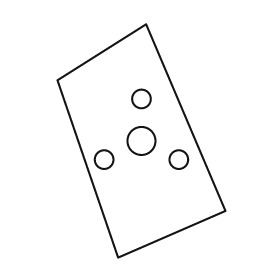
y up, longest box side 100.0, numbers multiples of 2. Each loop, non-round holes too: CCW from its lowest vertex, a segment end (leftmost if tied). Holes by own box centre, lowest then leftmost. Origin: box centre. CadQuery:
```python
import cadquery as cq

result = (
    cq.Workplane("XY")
    .moveTo(-10.0, -50.0)
    .lineTo(36.0, -30.0)
    .lineTo(2.0, 50.0)
    .lineTo(-36.0, 26.0)
    .close()
    .moveTo(-16.0, -8.0)
    .circle(4.0)
    .moveTo(16.0, -8.0)
    .circle(4.0)
    .moveTo(0.0, 0.0)
    .circle(6.0)
    .moveTo(0.0, 18.0)
    .circle(4.0)
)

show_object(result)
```